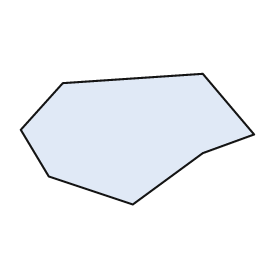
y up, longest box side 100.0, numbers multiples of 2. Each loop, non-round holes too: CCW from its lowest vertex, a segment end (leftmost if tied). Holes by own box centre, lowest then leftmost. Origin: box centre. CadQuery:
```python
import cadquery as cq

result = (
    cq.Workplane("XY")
    .moveTo(-2.0, -28.0)
    .lineTo(28.0, -6.0)
    .lineTo(50.0, 2.0)
    .lineTo(28.0, 28.0)
    .lineTo(-32.0, 24.0)
    .lineTo(-50.0, 4.0)
    .lineTo(-38.0, -16.0)
    .close()
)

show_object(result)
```